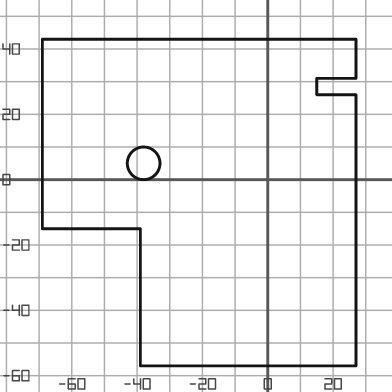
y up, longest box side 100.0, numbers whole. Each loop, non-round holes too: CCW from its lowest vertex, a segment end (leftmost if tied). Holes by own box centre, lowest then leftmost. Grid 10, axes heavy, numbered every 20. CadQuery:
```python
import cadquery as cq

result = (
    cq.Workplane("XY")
    .moveTo(-39.0, -57.0)
    .lineTo(27.0, -57.0)
    .lineTo(27.0, 26.0)
    .lineTo(15.0, 26.0)
    .lineTo(15.0, 31.0)
    .lineTo(27.0, 31.0)
    .lineTo(27.0, 43.0)
    .lineTo(-69.0, 43.0)
    .lineTo(-69.0, -15.0)
    .lineTo(-39.0, -15.0)
    .close()
    .moveTo(-38.0, 5.0)
    .circle(5.0)
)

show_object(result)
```